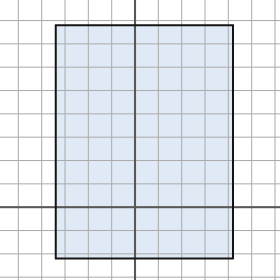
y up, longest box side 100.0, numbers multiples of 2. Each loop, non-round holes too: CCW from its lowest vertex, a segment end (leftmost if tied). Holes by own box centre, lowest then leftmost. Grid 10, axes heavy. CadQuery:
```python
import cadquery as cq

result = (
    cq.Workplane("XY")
    .moveTo(-34.0, -22.0)
    .lineTo(42.0, -22.0)
    .lineTo(42.0, 78.0)
    .lineTo(-34.0, 78.0)
    .close()
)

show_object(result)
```